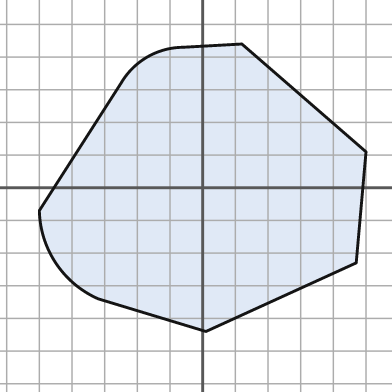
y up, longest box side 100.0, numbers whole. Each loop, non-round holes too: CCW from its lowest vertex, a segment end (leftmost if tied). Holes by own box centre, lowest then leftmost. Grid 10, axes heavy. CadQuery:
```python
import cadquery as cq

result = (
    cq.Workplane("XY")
    .moveTo(1.0, -44.0)
    .lineTo(47.0, -23.0)
    .lineTo(50.0, 11.0)
    .lineTo(12.0, 44.0)
    .lineTo(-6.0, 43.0)
    .threePointArc((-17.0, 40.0), (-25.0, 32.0))
    .lineTo(-50.0, -7.0)
    .threePointArc((-45.0, -23.0), (-32.0, -34.0))
    .close()
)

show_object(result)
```